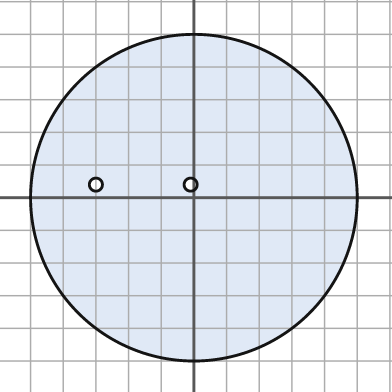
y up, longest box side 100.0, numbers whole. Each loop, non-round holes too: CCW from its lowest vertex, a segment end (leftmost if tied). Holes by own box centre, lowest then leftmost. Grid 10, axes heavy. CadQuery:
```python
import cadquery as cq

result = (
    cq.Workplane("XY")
    .moveTo(0.0, 0.0)
    .circle(50.0)
    .moveTo(-30.0, 4.0)
    .circle(2.0)
    .moveTo(-1.0, 4.0)
    .circle(2.0)
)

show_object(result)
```